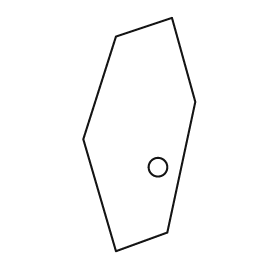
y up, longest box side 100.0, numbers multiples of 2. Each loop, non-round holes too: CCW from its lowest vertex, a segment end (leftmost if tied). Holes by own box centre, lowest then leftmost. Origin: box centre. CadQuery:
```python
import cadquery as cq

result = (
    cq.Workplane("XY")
    .moveTo(-10.0, -50.0)
    .lineTo(12.0, -42.0)
    .lineTo(24.0, 14.0)
    .lineTo(14.0, 50.0)
    .lineTo(-10.0, 42.0)
    .lineTo(-24.0, -2.0)
    .close()
    .moveTo(8.0, -14.0)
    .circle(4.0)
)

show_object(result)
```